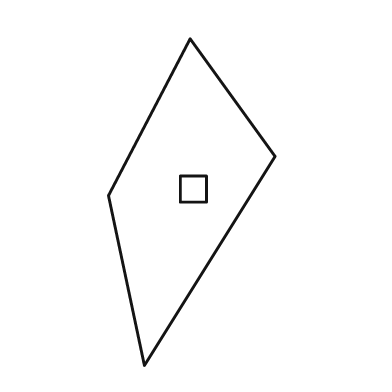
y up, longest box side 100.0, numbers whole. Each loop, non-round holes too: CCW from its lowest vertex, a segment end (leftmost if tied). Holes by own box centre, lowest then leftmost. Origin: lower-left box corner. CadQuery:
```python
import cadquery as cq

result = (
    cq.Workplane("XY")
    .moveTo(11.0, 0.0)
    .lineTo(51.0, 64.0)
    .lineTo(25.0, 100.0)
    .lineTo(0.0, 52.0)
    .close()
    .moveTo(22.0, 50.0)
    .lineTo(30.0, 50.0)
    .lineTo(30.0, 58.0)
    .lineTo(22.0, 58.0)
    .close()
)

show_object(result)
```